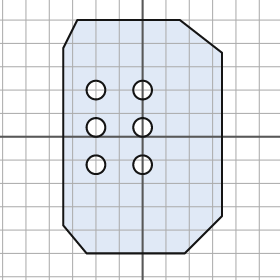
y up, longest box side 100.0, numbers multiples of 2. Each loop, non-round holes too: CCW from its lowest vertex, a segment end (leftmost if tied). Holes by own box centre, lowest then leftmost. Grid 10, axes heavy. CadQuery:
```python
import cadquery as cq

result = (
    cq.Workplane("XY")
    .moveTo(-24.0, -50.0)
    .lineTo(18.0, -50.0)
    .lineTo(34.0, -34.0)
    .lineTo(34.0, 36.0)
    .lineTo(16.0, 50.0)
    .lineTo(-28.0, 50.0)
    .lineTo(-34.0, 38.0)
    .lineTo(-34.0, -38.0)
    .close()
    .moveTo(-20.0, -12.0)
    .circle(4.0)
    .moveTo(0.0, -12.0)
    .circle(4.0)
    .moveTo(-20.0, 4.0)
    .circle(4.0)
    .moveTo(0.0, 4.0)
    .circle(4.0)
    .moveTo(-20.0, 20.0)
    .circle(4.0)
    .moveTo(0.0, 20.0)
    .circle(4.0)
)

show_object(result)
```